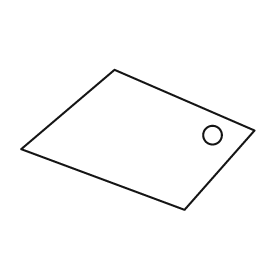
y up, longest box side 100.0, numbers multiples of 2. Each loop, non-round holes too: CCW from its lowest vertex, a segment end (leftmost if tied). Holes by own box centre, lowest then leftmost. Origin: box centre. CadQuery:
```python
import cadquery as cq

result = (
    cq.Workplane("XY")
    .moveTo(20.0, -30.0)
    .lineTo(50.0, 4.0)
    .lineTo(-10.0, 30.0)
    .lineTo(-50.0, -4.0)
    .close()
    .moveTo(32.0, 2.0)
    .circle(4.0)
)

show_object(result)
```